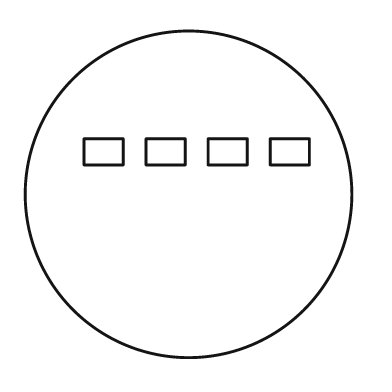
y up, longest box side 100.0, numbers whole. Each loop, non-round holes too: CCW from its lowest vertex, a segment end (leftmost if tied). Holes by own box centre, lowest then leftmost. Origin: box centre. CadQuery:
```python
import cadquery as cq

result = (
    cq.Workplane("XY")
    .moveTo(0.0, 0.0)
    .circle(50.0)
    .moveTo(-32.0, 9.0)
    .lineTo(-20.0, 9.0)
    .lineTo(-20.0, 17.0)
    .lineTo(-32.0, 17.0)
    .close()
    .moveTo(-13.0, 9.0)
    .lineTo(-1.0, 9.0)
    .lineTo(-1.0, 17.0)
    .lineTo(-13.0, 17.0)
    .close()
    .moveTo(6.0, 9.0)
    .lineTo(18.0, 9.0)
    .lineTo(18.0, 17.0)
    .lineTo(6.0, 17.0)
    .close()
    .moveTo(25.0, 9.0)
    .lineTo(37.0, 9.0)
    .lineTo(37.0, 17.0)
    .lineTo(25.0, 17.0)
    .close()
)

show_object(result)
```